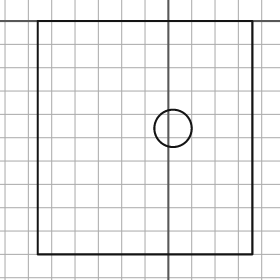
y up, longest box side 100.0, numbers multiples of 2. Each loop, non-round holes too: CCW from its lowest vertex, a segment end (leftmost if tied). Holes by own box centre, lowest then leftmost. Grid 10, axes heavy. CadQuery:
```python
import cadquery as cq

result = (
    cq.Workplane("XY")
    .moveTo(-56.0, -100.0)
    .lineTo(36.0, -100.0)
    .lineTo(36.0, 0.0)
    .lineTo(-56.0, 0.0)
    .close()
    .moveTo(2.0, -46.0)
    .circle(8.0)
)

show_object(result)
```